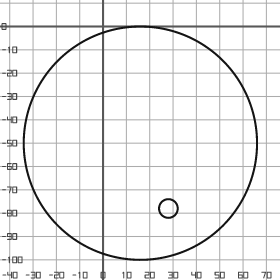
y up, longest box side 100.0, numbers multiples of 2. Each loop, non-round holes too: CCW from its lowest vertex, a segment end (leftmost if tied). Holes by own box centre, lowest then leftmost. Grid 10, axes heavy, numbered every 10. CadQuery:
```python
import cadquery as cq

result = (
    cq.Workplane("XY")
    .moveTo(16.0, -50.0)
    .circle(50.0)
    .moveTo(28.0, -78.0)
    .circle(4.0)
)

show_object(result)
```